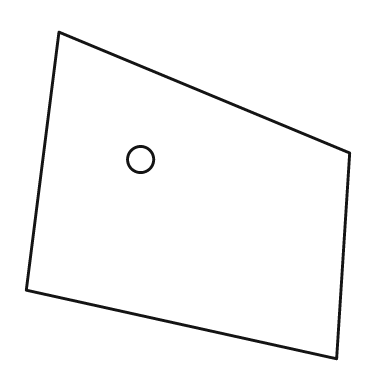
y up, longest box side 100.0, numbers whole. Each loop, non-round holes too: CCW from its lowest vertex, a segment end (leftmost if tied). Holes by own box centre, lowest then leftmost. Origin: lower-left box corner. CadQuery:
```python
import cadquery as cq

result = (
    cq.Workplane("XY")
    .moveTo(95.0, 0.0)
    .lineTo(99.0, 63.0)
    .lineTo(10.0, 100.0)
    .lineTo(0.0, 21.0)
    .close()
    .moveTo(35.0, 61.0)
    .circle(4.0)
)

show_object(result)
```